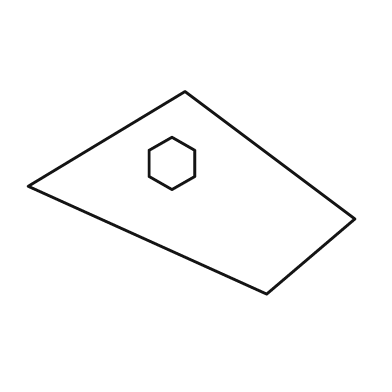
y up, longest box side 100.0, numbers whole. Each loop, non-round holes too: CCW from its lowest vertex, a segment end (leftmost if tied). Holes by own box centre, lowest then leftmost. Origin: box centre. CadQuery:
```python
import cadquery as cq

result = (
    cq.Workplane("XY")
    .moveTo(23.0, -31.0)
    .lineTo(50.0, -8.0)
    .lineTo(-2.0, 31.0)
    .lineTo(-50.0, 2.0)
    .close()
    .moveTo(-6.0, 1.0)
    .lineTo(1.0, 5.0)
    .lineTo(1.0, 13.0)
    .lineTo(-6.0, 17.0)
    .lineTo(-13.0, 13.0)
    .lineTo(-13.0, 5.0)
    .close()
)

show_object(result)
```